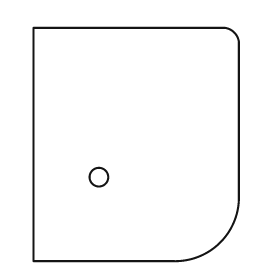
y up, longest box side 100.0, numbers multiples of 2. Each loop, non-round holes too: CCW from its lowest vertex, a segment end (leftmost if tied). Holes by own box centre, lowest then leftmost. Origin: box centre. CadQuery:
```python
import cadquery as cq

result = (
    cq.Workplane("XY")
    .moveTo(-44.0, -50.0)
    .lineTo(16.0, -50.0)
    .threePointArc((36.0, -42.0), (44.0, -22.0))
    .lineTo(44.0, 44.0)
    .threePointArc((42.0, 48.0), (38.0, 50.0))
    .lineTo(-44.0, 50.0)
    .close()
    .moveTo(-16.0, -14.0)
    .circle(4.0)
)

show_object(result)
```